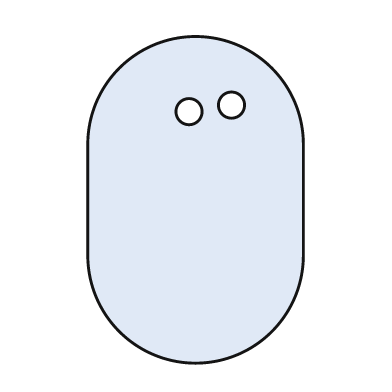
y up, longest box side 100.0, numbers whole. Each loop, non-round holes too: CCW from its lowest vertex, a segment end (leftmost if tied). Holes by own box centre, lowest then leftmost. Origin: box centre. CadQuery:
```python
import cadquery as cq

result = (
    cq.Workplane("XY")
    .moveTo(-33.0, -17.0)
    .threePointArc((0.0, -50.0), (33.0, -17.0))
    .lineTo(33.0, 17.0)
    .threePointArc((0.0, 50.0), (-33.0, 17.0))
    .close()
    .moveTo(-2.0, 27.0)
    .circle(4.0)
    .moveTo(11.0, 29.0)
    .circle(4.0)
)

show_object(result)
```